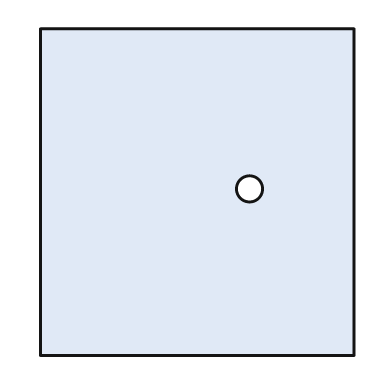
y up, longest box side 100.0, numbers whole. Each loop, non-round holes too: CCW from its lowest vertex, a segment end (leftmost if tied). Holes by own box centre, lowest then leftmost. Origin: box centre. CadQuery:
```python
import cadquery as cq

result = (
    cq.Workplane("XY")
    .moveTo(-48.0, -50.0)
    .lineTo(48.0, -50.0)
    .lineTo(48.0, 50.0)
    .lineTo(-48.0, 50.0)
    .close()
    .moveTo(16.0, 1.0)
    .circle(4.0)
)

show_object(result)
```